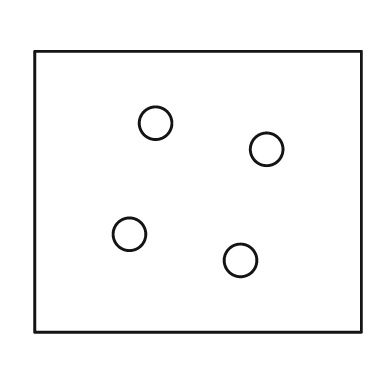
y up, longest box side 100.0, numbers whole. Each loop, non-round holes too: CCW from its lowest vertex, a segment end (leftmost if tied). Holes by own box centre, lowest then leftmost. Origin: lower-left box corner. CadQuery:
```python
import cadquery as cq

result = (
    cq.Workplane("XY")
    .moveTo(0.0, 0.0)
    .lineTo(100.0, 0.0)
    .lineTo(100.0, 86.0)
    .lineTo(0.0, 86.0)
    .close()
    .moveTo(63.0, 22.0)
    .circle(5.0)
    .moveTo(29.0, 30.0)
    .circle(5.0)
    .moveTo(71.0, 56.0)
    .circle(5.0)
    .moveTo(37.0, 64.0)
    .circle(5.0)
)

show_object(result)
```